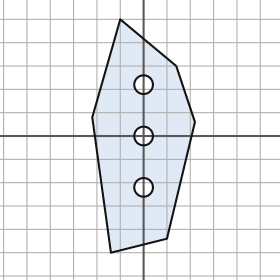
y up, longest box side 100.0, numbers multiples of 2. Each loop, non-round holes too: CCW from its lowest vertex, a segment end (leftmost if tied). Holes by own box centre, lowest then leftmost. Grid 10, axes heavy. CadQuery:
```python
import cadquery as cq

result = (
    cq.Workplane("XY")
    .moveTo(-14.0, -50.0)
    .lineTo(10.0, -44.0)
    .lineTo(22.0, 6.0)
    .lineTo(14.0, 30.0)
    .lineTo(-10.0, 50.0)
    .lineTo(-22.0, 8.0)
    .close()
    .moveTo(0.0, -22.0)
    .circle(4.0)
    .moveTo(0.0, 0.0)
    .circle(4.0)
    .moveTo(0.0, 22.0)
    .circle(4.0)
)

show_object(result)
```